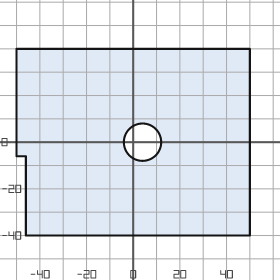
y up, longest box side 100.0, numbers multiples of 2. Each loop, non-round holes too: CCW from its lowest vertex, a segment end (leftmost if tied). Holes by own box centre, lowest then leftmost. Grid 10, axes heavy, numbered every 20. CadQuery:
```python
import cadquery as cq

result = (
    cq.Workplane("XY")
    .moveTo(-46.0, -40.0)
    .lineTo(50.0, -40.0)
    .lineTo(50.0, 40.0)
    .lineTo(-50.0, 40.0)
    .lineTo(-50.0, -6.0)
    .lineTo(-46.0, -6.0)
    .close()
    .moveTo(4.0, 0.0)
    .circle(8.0)
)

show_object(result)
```